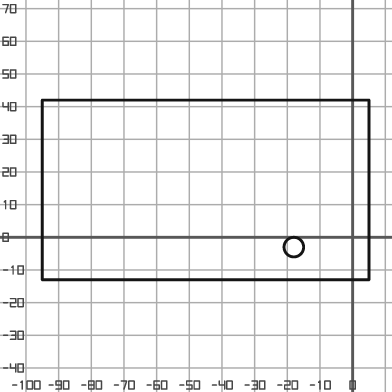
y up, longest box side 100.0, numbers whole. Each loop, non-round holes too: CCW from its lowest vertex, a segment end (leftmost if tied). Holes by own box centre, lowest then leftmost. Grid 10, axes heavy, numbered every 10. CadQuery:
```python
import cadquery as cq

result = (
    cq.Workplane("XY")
    .moveTo(-95.0, -13.0)
    .lineTo(5.0, -13.0)
    .lineTo(5.0, 42.0)
    .lineTo(-95.0, 42.0)
    .close()
    .moveTo(-18.0, -3.0)
    .circle(3.0)
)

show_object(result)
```